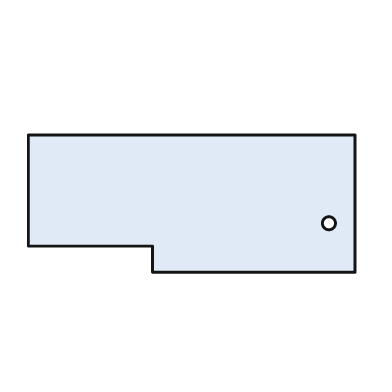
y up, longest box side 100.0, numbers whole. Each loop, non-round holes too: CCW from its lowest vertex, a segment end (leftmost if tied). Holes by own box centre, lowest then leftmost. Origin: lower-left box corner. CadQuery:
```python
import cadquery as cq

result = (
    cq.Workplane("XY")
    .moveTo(38.0, 0.0)
    .lineTo(100.0, 0.0)
    .lineTo(100.0, 42.0)
    .lineTo(0.0, 42.0)
    .lineTo(0.0, 8.0)
    .lineTo(38.0, 8.0)
    .close()
    .moveTo(92.0, 15.0)
    .circle(2.0)
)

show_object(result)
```